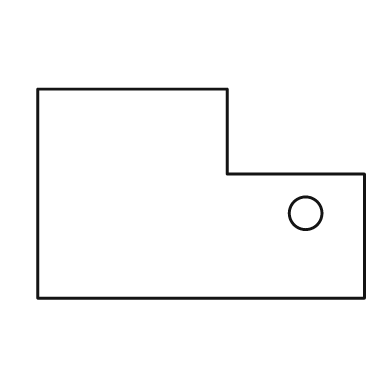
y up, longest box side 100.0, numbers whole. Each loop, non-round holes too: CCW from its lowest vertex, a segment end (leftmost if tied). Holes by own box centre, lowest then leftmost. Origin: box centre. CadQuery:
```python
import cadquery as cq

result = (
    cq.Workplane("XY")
    .moveTo(-50.0, -32.0)
    .lineTo(50.0, -32.0)
    .lineTo(50.0, 6.0)
    .lineTo(8.0, 6.0)
    .lineTo(8.0, 32.0)
    .lineTo(-50.0, 32.0)
    .close()
    .moveTo(32.0, -6.0)
    .circle(5.0)
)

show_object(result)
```